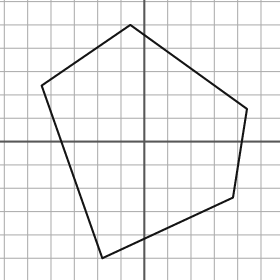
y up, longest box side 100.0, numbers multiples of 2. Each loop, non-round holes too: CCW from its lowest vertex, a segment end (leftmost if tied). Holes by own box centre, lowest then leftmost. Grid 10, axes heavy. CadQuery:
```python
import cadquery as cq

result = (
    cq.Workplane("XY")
    .moveTo(-18.0, -50.0)
    .lineTo(38.0, -24.0)
    .lineTo(44.0, 14.0)
    .lineTo(-6.0, 50.0)
    .lineTo(-44.0, 24.0)
    .close()
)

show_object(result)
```